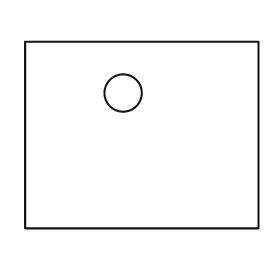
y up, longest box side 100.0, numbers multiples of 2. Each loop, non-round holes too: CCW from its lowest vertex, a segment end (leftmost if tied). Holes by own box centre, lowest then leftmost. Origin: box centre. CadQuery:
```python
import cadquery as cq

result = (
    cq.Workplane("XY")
    .moveTo(-50.0, -40.0)
    .lineTo(50.0, -40.0)
    .lineTo(50.0, 40.0)
    .lineTo(-50.0, 40.0)
    .close()
    .moveTo(-8.0, 18.0)
    .circle(8.0)
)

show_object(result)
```